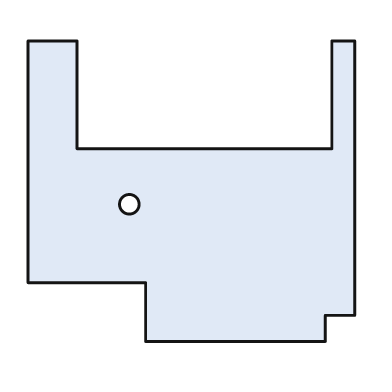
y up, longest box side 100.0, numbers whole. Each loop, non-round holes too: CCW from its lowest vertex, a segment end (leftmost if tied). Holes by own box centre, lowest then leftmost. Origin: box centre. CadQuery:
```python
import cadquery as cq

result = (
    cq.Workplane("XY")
    .moveTo(-14.0, -46.0)
    .lineTo(41.0, -46.0)
    .lineTo(41.0, -38.0)
    .lineTo(50.0, -38.0)
    .lineTo(50.0, 46.0)
    .lineTo(43.0, 46.0)
    .lineTo(43.0, 13.0)
    .lineTo(-35.0, 13.0)
    .lineTo(-35.0, 46.0)
    .lineTo(-50.0, 46.0)
    .lineTo(-50.0, -28.0)
    .lineTo(-14.0, -28.0)
    .close()
    .moveTo(-19.0, -4.0)
    .circle(3.0)
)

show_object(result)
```